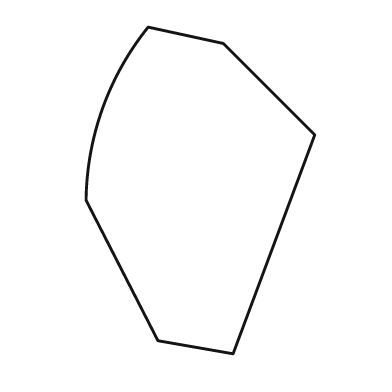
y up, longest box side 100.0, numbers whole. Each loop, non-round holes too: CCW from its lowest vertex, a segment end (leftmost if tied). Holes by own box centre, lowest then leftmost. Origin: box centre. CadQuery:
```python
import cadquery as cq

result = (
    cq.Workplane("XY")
    .moveTo(10.0, -50.0)
    .lineTo(35.0, 17.0)
    .lineTo(7.0, 45.0)
    .lineTo(-16.0, 50.0)
    .threePointArc((-30.0, 25.0), (-35.0, -3.0))
    .lineTo(-13.0, -46.0)
    .close()
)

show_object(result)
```